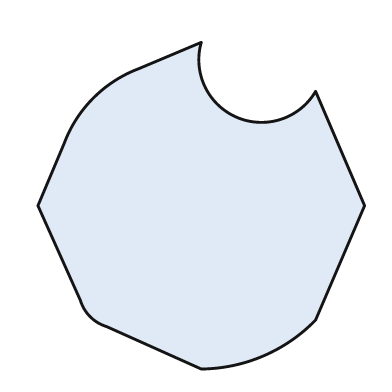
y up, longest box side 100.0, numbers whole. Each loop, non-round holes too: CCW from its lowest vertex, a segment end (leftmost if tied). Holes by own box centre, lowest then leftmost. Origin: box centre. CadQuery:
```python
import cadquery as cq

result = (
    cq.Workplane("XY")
    .moveTo(0.0, -50.0)
    .threePointArc((19.0, -46.0), (35.0, -35.0))
    .lineTo(50.0, 0.0)
    .lineTo(35.0, 35.0)
    .threePointArc((11.0, 27.0), (0.0, 50.0))
    .lineTo(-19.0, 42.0)
    .threePointArc((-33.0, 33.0), (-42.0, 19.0))
    .lineTo(-50.0, 0.0)
    .lineTo(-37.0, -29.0)
    .threePointArc((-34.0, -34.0), (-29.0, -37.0))
    .close()
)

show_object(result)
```